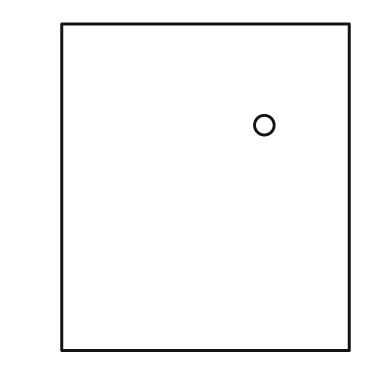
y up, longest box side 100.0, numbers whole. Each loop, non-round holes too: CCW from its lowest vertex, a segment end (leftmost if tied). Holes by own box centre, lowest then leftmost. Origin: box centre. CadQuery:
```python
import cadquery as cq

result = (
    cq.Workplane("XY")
    .moveTo(-44.0, -50.0)
    .lineTo(44.0, -50.0)
    .lineTo(44.0, 50.0)
    .lineTo(-44.0, 50.0)
    .close()
    .moveTo(18.0, 19.0)
    .circle(3.0)
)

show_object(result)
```